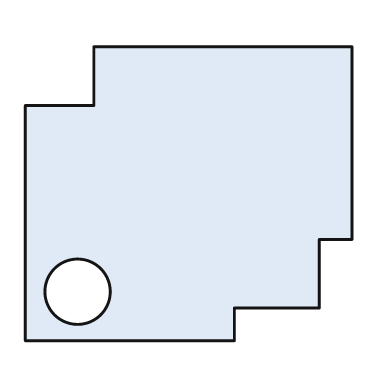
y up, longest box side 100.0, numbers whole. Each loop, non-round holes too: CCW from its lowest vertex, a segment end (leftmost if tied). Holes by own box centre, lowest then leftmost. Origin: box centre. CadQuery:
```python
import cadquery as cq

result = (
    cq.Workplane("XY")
    .moveTo(-50.0, -45.0)
    .lineTo(14.0, -45.0)
    .lineTo(14.0, -35.0)
    .lineTo(40.0, -35.0)
    .lineTo(40.0, -14.0)
    .lineTo(50.0, -14.0)
    .lineTo(50.0, 45.0)
    .lineTo(-29.0, 45.0)
    .lineTo(-29.0, 27.0)
    .lineTo(-50.0, 27.0)
    .close()
    .moveTo(-34.0, -30.0)
    .circle(10.0)
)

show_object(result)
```